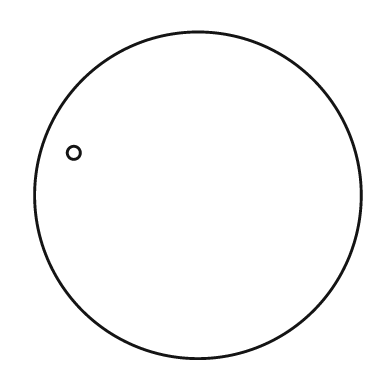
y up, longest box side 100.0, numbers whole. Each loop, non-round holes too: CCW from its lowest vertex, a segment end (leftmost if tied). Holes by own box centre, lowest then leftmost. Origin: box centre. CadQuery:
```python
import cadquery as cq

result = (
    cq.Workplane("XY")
    .moveTo(0.0, 0.0)
    .circle(50.0)
    .moveTo(-38.0, 13.0)
    .circle(2.0)
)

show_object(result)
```